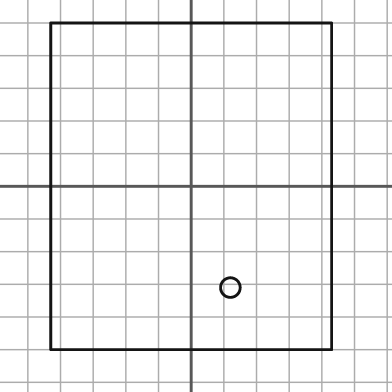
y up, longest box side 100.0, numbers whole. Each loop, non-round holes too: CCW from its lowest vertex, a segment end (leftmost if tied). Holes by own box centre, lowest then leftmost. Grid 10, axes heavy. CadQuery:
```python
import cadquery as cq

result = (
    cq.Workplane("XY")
    .moveTo(-43.0, -50.0)
    .lineTo(43.0, -50.0)
    .lineTo(43.0, 50.0)
    .lineTo(-43.0, 50.0)
    .close()
    .moveTo(12.0, -31.0)
    .circle(3.0)
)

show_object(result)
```